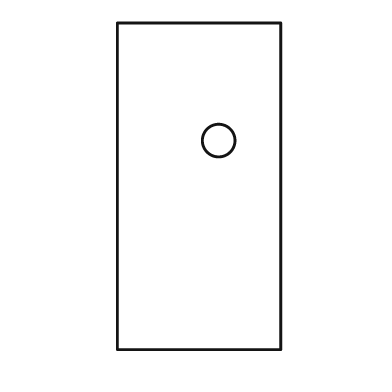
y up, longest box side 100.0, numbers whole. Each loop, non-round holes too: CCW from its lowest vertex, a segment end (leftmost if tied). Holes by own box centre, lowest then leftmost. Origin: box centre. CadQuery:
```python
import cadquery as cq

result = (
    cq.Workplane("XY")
    .moveTo(-25.0, -50.0)
    .lineTo(25.0, -50.0)
    .lineTo(25.0, 50.0)
    .lineTo(-25.0, 50.0)
    .close()
    .moveTo(6.0, 14.0)
    .circle(5.0)
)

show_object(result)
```